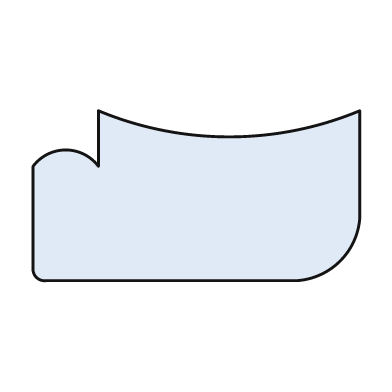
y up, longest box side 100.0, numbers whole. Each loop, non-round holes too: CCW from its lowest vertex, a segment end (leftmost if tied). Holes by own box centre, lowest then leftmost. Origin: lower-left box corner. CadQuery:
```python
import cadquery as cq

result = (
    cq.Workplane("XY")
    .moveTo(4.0, 0.0)
    .lineTo(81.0, 0.0)
    .threePointArc((94.0, 6.0), (100.0, 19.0))
    .lineTo(100.0, 52.0)
    .threePointArc((60.0, 44.0), (20.0, 52.0))
    .lineTo(20.0, 35.0)
    .threePointArc((10.0, 40.0), (0.0, 35.0))
    .lineTo(0.0, 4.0)
    .threePointArc((1.0, 1.0), (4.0, 0.0))
    .close()
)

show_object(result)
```